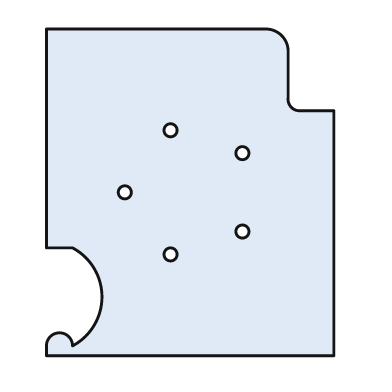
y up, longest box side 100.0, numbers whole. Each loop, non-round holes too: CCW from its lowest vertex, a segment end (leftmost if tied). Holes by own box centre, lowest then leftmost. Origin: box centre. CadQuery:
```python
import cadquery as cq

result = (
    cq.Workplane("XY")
    .moveTo(-44.0, -50.0)
    .lineTo(44.0, -50.0)
    .lineTo(44.0, 25.0)
    .lineTo(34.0, 25.0)
    .threePointArc((31.0, 26.0), (30.0, 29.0))
    .lineTo(30.0, 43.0)
    .threePointArc((28.0, 48.0), (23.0, 50.0))
    .lineTo(-44.0, 50.0)
    .lineTo(-44.0, -17.0)
    .lineTo(-36.0, -17.0)
    .threePointArc((-27.0, -32.0), (-36.0, -47.0))
    .threePointArc((-40.0, -43.0), (-44.0, -47.0))
    .close()
    .moveTo(-6.0, -19.0)
    .circle(2.0)
    .moveTo(16.0, -12.0)
    .circle(2.0)
    .moveTo(-20.0, 0.0)
    .circle(2.0)
    .moveTo(16.0, 12.0)
    .circle(2.0)
    .moveTo(-6.0, 19.0)
    .circle(2.0)
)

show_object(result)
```